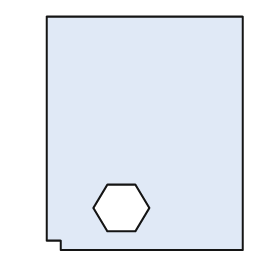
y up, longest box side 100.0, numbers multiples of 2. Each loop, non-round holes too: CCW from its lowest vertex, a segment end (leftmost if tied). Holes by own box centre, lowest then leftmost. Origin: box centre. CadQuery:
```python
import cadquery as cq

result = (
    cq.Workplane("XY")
    .moveTo(-36.0, -50.0)
    .lineTo(42.0, -50.0)
    .lineTo(42.0, 50.0)
    .lineTo(-42.0, 50.0)
    .lineTo(-42.0, -46.0)
    .lineTo(-36.0, -46.0)
    .close()
    .moveTo(-16.0, -42.0)
    .lineTo(-4.0, -42.0)
    .lineTo(2.0, -32.0)
    .lineTo(-4.0, -22.0)
    .lineTo(-16.0, -22.0)
    .lineTo(-22.0, -32.0)
    .close()
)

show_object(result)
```